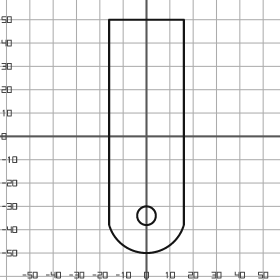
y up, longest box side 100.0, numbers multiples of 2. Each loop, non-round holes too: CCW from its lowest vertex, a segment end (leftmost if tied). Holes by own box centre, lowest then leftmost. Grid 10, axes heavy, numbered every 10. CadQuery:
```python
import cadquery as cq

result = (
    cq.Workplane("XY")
    .moveTo(-16.0, -38.0)
    .threePointArc((0.0, -50.0), (16.0, -38.0))
    .lineTo(16.0, 50.0)
    .lineTo(-16.0, 50.0)
    .close()
    .moveTo(0.0, -34.0)
    .circle(4.0)
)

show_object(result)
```